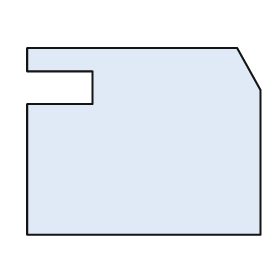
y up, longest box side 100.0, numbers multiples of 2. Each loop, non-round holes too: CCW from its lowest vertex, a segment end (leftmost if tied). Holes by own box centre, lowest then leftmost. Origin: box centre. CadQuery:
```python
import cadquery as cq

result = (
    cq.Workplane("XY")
    .moveTo(-50.0, -40.0)
    .lineTo(50.0, -40.0)
    .lineTo(50.0, 22.0)
    .lineTo(40.0, 40.0)
    .lineTo(-50.0, 40.0)
    .lineTo(-50.0, 30.0)
    .lineTo(-22.0, 30.0)
    .lineTo(-22.0, 16.0)
    .lineTo(-50.0, 16.0)
    .close()
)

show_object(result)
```